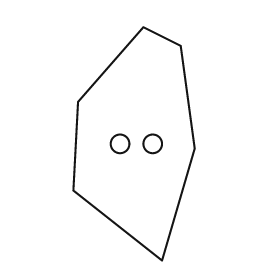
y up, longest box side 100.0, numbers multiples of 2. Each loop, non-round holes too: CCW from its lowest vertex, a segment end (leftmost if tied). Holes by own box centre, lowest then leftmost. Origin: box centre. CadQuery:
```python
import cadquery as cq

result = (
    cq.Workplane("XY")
    .moveTo(12.0, -50.0)
    .lineTo(26.0, -2.0)
    .lineTo(20.0, 42.0)
    .lineTo(4.0, 50.0)
    .lineTo(-24.0, 18.0)
    .lineTo(-26.0, -20.0)
    .close()
    .moveTo(-6.0, 0.0)
    .circle(4.0)
    .moveTo(8.0, 0.0)
    .circle(4.0)
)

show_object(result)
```